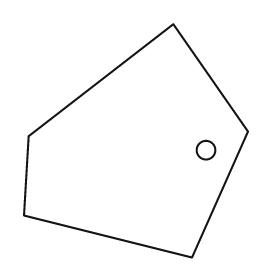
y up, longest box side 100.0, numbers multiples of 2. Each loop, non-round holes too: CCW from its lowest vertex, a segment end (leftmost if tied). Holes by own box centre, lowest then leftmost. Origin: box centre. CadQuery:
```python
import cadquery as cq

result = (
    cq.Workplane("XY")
    .moveTo(24.0, -50.0)
    .lineTo(48.0, 4.0)
    .lineTo(16.0, 50.0)
    .lineTo(-46.0, 2.0)
    .lineTo(-48.0, -32.0)
    .close()
    .moveTo(30.0, -4.0)
    .circle(4.0)
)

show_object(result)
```